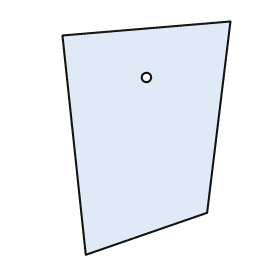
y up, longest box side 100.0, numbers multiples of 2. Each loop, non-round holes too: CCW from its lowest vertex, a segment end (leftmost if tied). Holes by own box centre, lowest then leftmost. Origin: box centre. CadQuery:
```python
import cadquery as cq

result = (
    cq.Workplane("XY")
    .moveTo(-26.0, -50.0)
    .lineTo(26.0, -32.0)
    .lineTo(36.0, 50.0)
    .lineTo(-36.0, 44.0)
    .close()
    .moveTo(0.0, 26.0)
    .circle(2.0)
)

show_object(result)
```